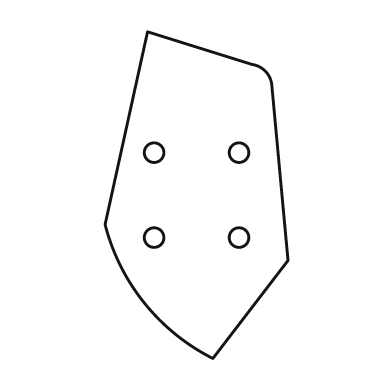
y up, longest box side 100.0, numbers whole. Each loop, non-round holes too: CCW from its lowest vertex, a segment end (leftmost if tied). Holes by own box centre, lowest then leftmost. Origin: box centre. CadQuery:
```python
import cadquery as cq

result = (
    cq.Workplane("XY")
    .moveTo(5.0, -50.0)
    .lineTo(28.0, -20.0)
    .lineTo(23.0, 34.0)
    .threePointArc((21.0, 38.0), (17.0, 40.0))
    .lineTo(-15.0, 50.0)
    .lineTo(-28.0, -9.0)
    .threePointArc((-16.0, -33.0), (5.0, -50.0))
    .close()
    .moveTo(-13.0, -13.0)
    .circle(3.0)
    .moveTo(13.0, -13.0)
    .circle(3.0)
    .moveTo(-13.0, 13.0)
    .circle(3.0)
    .moveTo(13.0, 13.0)
    .circle(3.0)
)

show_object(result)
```